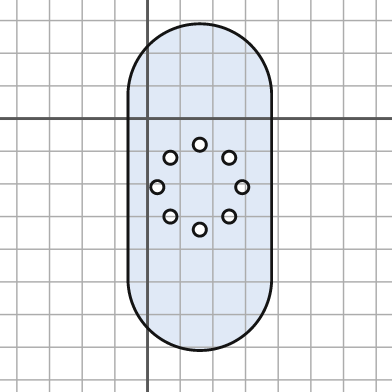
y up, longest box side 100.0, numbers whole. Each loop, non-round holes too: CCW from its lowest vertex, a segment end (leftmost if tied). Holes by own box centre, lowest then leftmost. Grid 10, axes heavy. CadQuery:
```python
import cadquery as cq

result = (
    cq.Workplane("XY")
    .moveTo(-6.0, -49.0)
    .threePointArc((16.0, -71.0), (38.0, -49.0))
    .lineTo(38.0, 7.0)
    .threePointArc((16.0, 29.0), (-6.0, 7.0))
    .close()
    .moveTo(16.0, -34.0)
    .circle(2.0)
    .moveTo(7.0, -30.0)
    .circle(2.0)
    .moveTo(25.0, -30.0)
    .circle(2.0)
    .moveTo(3.0, -21.0)
    .circle(2.0)
    .moveTo(29.0, -21.0)
    .circle(2.0)
    .moveTo(7.0, -12.0)
    .circle(2.0)
    .moveTo(25.0, -12.0)
    .circle(2.0)
    .moveTo(16.0, -8.0)
    .circle(2.0)
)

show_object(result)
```